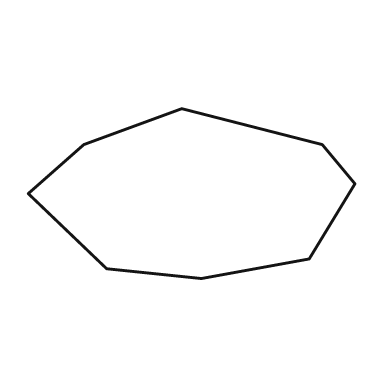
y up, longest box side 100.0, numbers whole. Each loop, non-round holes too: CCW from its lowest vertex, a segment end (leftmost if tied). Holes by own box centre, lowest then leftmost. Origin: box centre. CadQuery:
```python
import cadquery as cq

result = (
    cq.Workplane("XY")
    .moveTo(3.0, -26.0)
    .lineTo(36.0, -20.0)
    .lineTo(50.0, 3.0)
    .lineTo(40.0, 15.0)
    .lineTo(-3.0, 26.0)
    .lineTo(-33.0, 15.0)
    .lineTo(-50.0, 0.0)
    .lineTo(-26.0, -23.0)
    .close()
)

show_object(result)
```